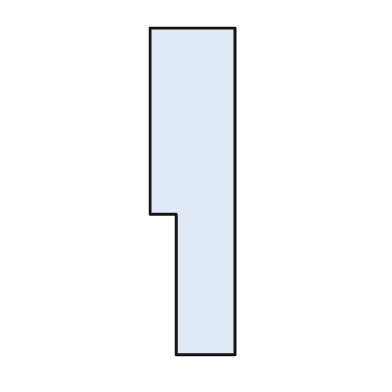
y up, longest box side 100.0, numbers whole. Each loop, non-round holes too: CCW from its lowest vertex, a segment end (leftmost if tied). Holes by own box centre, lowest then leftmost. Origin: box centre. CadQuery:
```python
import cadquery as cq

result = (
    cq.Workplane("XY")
    .moveTo(-5.0, -50.0)
    .lineTo(13.0, -50.0)
    .lineTo(13.0, 50.0)
    .lineTo(-13.0, 50.0)
    .lineTo(-13.0, -7.0)
    .lineTo(-5.0, -7.0)
    .close()
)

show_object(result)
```